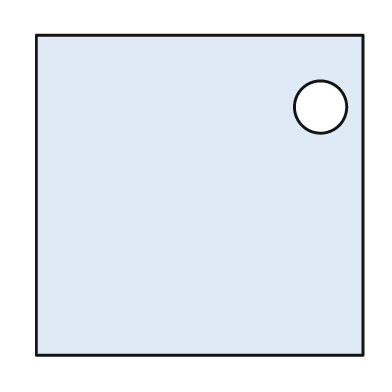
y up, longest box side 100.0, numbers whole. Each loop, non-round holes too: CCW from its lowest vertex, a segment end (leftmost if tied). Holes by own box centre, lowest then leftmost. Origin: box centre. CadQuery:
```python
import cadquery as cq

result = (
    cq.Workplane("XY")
    .moveTo(-50.0, -49.0)
    .lineTo(50.0, -49.0)
    .lineTo(50.0, 49.0)
    .lineTo(-50.0, 49.0)
    .close()
    .moveTo(37.0, 27.0)
    .circle(8.0)
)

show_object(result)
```